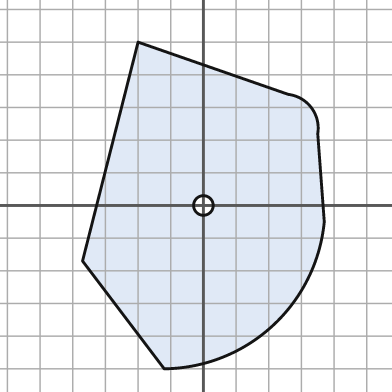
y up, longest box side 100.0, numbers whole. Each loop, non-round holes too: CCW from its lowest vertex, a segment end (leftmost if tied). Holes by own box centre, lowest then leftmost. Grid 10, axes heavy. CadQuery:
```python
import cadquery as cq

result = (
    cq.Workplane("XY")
    .moveTo(-12.0, -50.0)
    .threePointArc((21.0, -37.0), (37.0, -5.0))
    .lineTo(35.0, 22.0)
    .threePointArc((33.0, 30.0), (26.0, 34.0))
    .lineTo(-20.0, 50.0)
    .lineTo(-37.0, -17.0)
    .close()
    .moveTo(0.0, 0.0)
    .circle(3.0)
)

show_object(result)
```